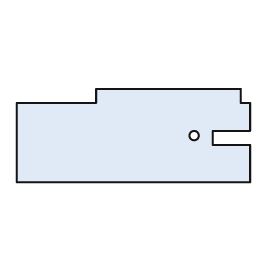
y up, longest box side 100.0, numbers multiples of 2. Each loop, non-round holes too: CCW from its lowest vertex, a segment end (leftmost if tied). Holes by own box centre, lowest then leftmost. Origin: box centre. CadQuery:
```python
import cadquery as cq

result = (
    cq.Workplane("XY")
    .moveTo(-50.0, -20.0)
    .lineTo(50.0, -20.0)
    .lineTo(50.0, -4.0)
    .lineTo(34.0, -4.0)
    .lineTo(34.0, 2.0)
    .lineTo(50.0, 2.0)
    .lineTo(50.0, 14.0)
    .lineTo(46.0, 14.0)
    .lineTo(46.0, 20.0)
    .lineTo(-16.0, 20.0)
    .lineTo(-16.0, 14.0)
    .lineTo(-50.0, 14.0)
    .close()
    .moveTo(26.0, 0.0)
    .circle(2.0)
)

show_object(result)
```